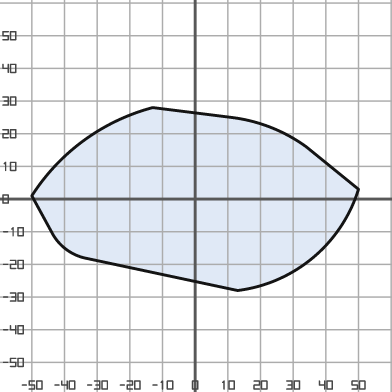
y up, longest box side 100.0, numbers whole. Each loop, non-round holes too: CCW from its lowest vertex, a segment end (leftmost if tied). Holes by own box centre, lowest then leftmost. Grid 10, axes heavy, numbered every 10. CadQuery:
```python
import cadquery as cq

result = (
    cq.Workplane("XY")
    .moveTo(13.0, -28.0)
    .threePointArc((36.0, -18.0), (50.0, 3.0))
    .lineTo(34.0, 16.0)
    .threePointArc((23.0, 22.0), (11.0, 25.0))
    .lineTo(-13.0, 28.0)
    .threePointArc((-34.0, 18.0), (-50.0, 1.0))
    .lineTo(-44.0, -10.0)
    .threePointArc((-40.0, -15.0), (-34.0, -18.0))
    .close()
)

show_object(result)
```